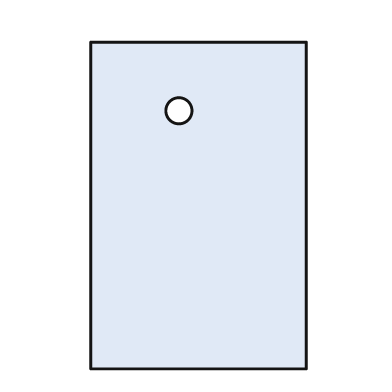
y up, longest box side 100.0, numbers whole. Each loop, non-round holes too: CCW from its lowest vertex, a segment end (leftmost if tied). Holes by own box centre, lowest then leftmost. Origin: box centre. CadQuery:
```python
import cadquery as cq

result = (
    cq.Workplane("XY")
    .moveTo(-33.0, -50.0)
    .lineTo(33.0, -50.0)
    .lineTo(33.0, 50.0)
    .lineTo(-33.0, 50.0)
    .close()
    .moveTo(-6.0, 29.0)
    .circle(4.0)
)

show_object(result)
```